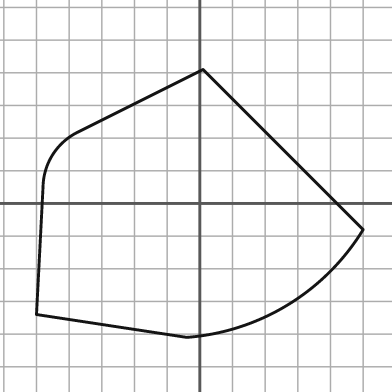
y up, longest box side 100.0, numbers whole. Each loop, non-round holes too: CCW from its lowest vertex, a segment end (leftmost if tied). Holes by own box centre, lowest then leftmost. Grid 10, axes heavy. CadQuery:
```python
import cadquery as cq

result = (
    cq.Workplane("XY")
    .moveTo(-4.0, -41.0)
    .threePointArc((27.0, -31.0), (50.0, -8.0))
    .lineTo(1.0, 41.0)
    .lineTo(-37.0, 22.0)
    .threePointArc((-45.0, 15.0), (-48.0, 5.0))
    .lineTo(-50.0, -34.0)
    .close()
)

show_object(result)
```